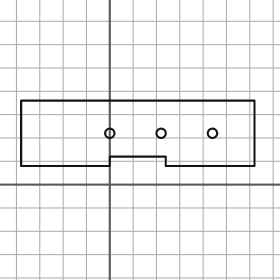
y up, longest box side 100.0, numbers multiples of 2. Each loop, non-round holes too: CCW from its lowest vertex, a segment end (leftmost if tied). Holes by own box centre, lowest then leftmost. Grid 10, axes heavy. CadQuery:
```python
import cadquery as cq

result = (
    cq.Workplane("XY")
    .moveTo(-38.0, 8.0)
    .lineTo(0.0, 8.0)
    .lineTo(0.0, 12.0)
    .lineTo(24.0, 12.0)
    .lineTo(24.0, 8.0)
    .lineTo(62.0, 8.0)
    .lineTo(62.0, 36.0)
    .lineTo(-38.0, 36.0)
    .close()
    .moveTo(0.0, 22.0)
    .circle(2.0)
    .moveTo(22.0, 22.0)
    .circle(2.0)
    .moveTo(44.0, 22.0)
    .circle(2.0)
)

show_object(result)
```